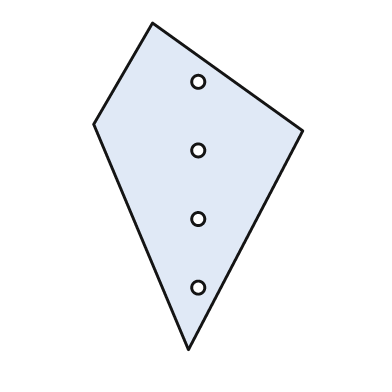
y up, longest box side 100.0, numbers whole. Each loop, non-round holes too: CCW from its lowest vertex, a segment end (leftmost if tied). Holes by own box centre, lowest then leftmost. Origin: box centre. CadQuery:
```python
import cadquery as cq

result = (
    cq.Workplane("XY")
    .moveTo(-3.0, -50.0)
    .lineTo(32.0, 17.0)
    .lineTo(-14.0, 50.0)
    .lineTo(-32.0, 19.0)
    .close()
    .moveTo(0.0, -31.0)
    .circle(2.0)
    .moveTo(0.0, -10.0)
    .circle(2.0)
    .moveTo(0.0, 11.0)
    .circle(2.0)
    .moveTo(0.0, 32.0)
    .circle(2.0)
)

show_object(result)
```